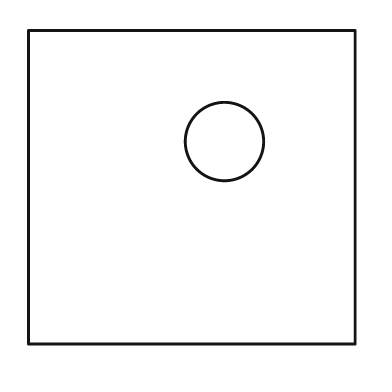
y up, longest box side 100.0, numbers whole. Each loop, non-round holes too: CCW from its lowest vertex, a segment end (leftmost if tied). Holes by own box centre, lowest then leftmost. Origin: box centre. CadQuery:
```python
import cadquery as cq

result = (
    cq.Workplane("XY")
    .moveTo(-50.0, -48.0)
    .lineTo(50.0, -48.0)
    .lineTo(50.0, 48.0)
    .lineTo(-50.0, 48.0)
    .close()
    .moveTo(10.0, 14.0)
    .circle(12.0)
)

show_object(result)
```